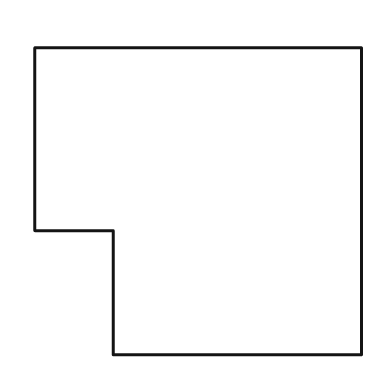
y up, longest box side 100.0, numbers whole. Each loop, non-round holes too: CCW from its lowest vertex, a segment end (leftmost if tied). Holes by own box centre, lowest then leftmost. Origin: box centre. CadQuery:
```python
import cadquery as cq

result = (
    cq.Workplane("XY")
    .moveTo(-26.0, -47.0)
    .lineTo(50.0, -47.0)
    .lineTo(50.0, 47.0)
    .lineTo(-50.0, 47.0)
    .lineTo(-50.0, -9.0)
    .lineTo(-26.0, -9.0)
    .close()
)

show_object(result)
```